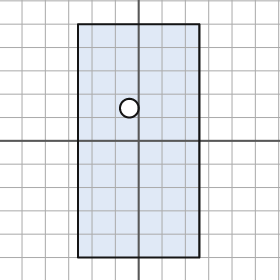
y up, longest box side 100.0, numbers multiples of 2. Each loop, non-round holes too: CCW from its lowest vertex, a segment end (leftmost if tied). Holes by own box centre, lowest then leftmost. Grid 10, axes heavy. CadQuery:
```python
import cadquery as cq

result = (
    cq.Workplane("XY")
    .moveTo(-26.0, -50.0)
    .lineTo(26.0, -50.0)
    .lineTo(26.0, 50.0)
    .lineTo(-26.0, 50.0)
    .close()
    .moveTo(-4.0, 14.0)
    .circle(4.0)
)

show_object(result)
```